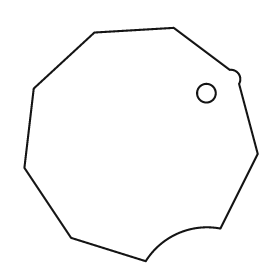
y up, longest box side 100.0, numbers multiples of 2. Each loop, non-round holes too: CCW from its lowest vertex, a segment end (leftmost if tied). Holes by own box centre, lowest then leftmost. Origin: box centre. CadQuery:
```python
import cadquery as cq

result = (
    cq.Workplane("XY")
    .moveTo(2.0, -50.0)
    .threePointArc((16.0, -38.0), (34.0, -36.0))
    .lineTo(50.0, -4.0)
    .lineTo(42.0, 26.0)
    .threePointArc((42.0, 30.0), (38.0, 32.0))
    .lineTo(14.0, 50.0)
    .lineTo(-20.0, 48.0)
    .lineTo(-46.0, 24.0)
    .lineTo(-50.0, -10.0)
    .lineTo(-30.0, -40.0)
    .close()
    .moveTo(28.0, 22.0)
    .circle(4.0)
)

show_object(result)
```